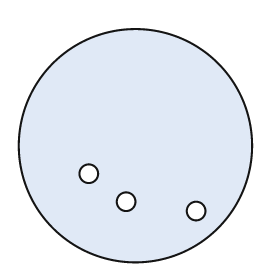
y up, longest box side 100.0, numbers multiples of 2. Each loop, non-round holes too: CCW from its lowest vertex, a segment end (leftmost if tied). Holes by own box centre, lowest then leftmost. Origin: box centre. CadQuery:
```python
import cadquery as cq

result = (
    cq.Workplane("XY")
    .moveTo(0.0, 0.0)
    .circle(50.0)
    .moveTo(26.0, -28.0)
    .circle(4.0)
    .moveTo(-4.0, -24.0)
    .circle(4.0)
    .moveTo(-20.0, -12.0)
    .circle(4.0)
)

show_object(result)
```